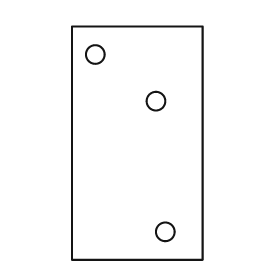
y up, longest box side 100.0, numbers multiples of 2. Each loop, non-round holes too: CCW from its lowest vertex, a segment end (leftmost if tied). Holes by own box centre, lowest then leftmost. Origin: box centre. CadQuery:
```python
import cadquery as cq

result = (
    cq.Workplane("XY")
    .moveTo(-28.0, -50.0)
    .lineTo(28.0, -50.0)
    .lineTo(28.0, 50.0)
    .lineTo(-28.0, 50.0)
    .close()
    .moveTo(12.0, -38.0)
    .circle(4.0)
    .moveTo(8.0, 18.0)
    .circle(4.0)
    .moveTo(-18.0, 38.0)
    .circle(4.0)
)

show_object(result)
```